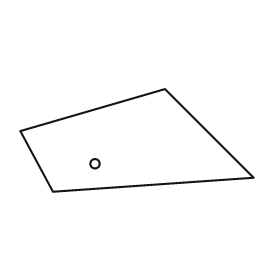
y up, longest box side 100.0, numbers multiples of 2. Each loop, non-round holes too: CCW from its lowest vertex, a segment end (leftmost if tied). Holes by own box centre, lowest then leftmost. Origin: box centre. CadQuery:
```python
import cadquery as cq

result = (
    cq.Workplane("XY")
    .moveTo(-36.0, -22.0)
    .lineTo(50.0, -16.0)
    .lineTo(12.0, 22.0)
    .lineTo(-50.0, 4.0)
    .close()
    .moveTo(-18.0, -10.0)
    .circle(2.0)
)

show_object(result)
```